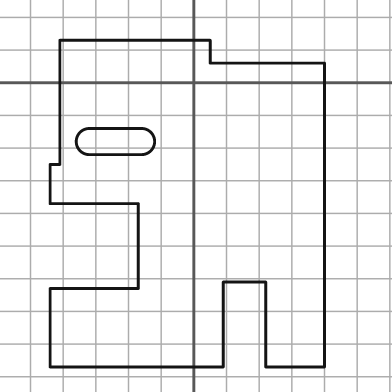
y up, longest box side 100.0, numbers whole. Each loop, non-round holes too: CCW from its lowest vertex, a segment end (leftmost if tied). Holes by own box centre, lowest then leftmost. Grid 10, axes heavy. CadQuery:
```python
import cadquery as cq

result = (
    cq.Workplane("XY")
    .moveTo(-44.0, -87.0)
    .lineTo(9.0, -87.0)
    .lineTo(9.0, -61.0)
    .lineTo(22.0, -61.0)
    .lineTo(22.0, -87.0)
    .lineTo(40.0, -87.0)
    .lineTo(40.0, 6.0)
    .lineTo(5.0, 6.0)
    .lineTo(5.0, 13.0)
    .lineTo(-41.0, 13.0)
    .lineTo(-41.0, -25.0)
    .lineTo(-44.0, -25.0)
    .lineTo(-44.0, -37.0)
    .lineTo(-17.0, -37.0)
    .lineTo(-17.0, -63.0)
    .lineTo(-44.0, -63.0)
    .close()
    .moveTo(-32.0, -22.0)
    .lineTo(-16.0, -22.0)
    .threePointArc((-12.0, -18.0), (-16.0, -14.0))
    .lineTo(-32.0, -14.0)
    .threePointArc((-36.0, -18.0), (-32.0, -22.0))
    .close()
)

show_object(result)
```